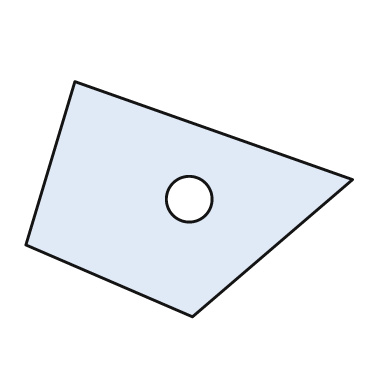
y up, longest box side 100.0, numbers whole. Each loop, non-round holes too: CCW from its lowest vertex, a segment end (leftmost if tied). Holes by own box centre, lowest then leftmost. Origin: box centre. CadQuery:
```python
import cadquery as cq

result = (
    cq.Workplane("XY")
    .moveTo(1.0, -36.0)
    .lineTo(50.0, 6.0)
    .lineTo(-35.0, 36.0)
    .lineTo(-50.0, -14.0)
    .close()
    .moveTo(0.0, 0.0)
    .circle(7.0)
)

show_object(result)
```